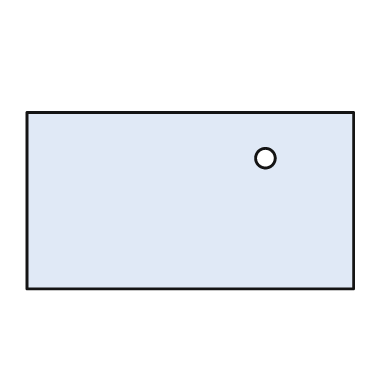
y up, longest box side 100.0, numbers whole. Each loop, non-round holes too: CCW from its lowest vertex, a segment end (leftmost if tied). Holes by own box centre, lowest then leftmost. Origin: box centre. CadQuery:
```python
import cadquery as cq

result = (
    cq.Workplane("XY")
    .moveTo(-50.0, -27.0)
    .lineTo(50.0, -27.0)
    .lineTo(50.0, 27.0)
    .lineTo(-50.0, 27.0)
    .close()
    .moveTo(23.0, 13.0)
    .circle(3.0)
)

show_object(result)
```